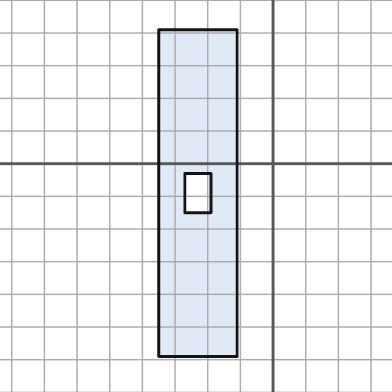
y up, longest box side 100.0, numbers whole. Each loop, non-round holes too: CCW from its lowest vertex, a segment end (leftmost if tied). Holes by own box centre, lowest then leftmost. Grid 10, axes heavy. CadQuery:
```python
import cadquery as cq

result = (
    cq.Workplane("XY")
    .moveTo(-35.0, -59.0)
    .lineTo(-11.0, -59.0)
    .lineTo(-11.0, 41.0)
    .lineTo(-35.0, 41.0)
    .close()
    .moveTo(-27.0, -15.0)
    .lineTo(-19.0, -15.0)
    .lineTo(-19.0, -3.0)
    .lineTo(-27.0, -3.0)
    .close()
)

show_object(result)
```